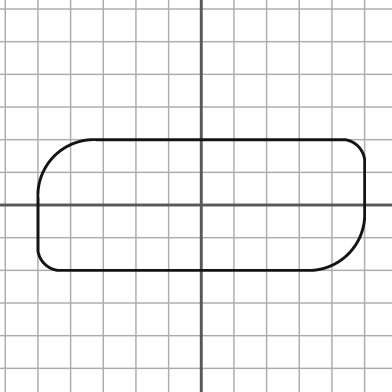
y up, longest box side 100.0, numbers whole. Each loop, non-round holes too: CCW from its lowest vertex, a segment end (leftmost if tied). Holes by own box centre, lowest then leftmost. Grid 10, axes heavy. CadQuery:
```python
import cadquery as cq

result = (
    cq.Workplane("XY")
    .moveTo(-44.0, -20.0)
    .lineTo(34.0, -20.0)
    .threePointArc((45.0, -15.0), (50.0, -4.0))
    .lineTo(50.0, 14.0)
    .threePointArc((48.0, 18.0), (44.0, 20.0))
    .lineTo(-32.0, 20.0)
    .threePointArc((-45.0, 15.0), (-50.0, 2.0))
    .lineTo(-50.0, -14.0)
    .threePointArc((-48.0, -18.0), (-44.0, -20.0))
    .close()
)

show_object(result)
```